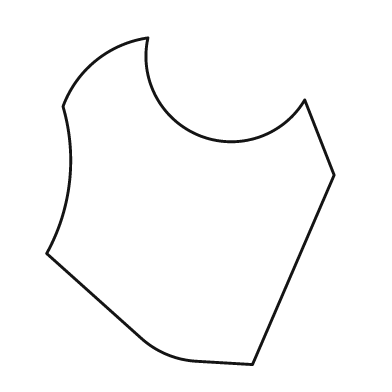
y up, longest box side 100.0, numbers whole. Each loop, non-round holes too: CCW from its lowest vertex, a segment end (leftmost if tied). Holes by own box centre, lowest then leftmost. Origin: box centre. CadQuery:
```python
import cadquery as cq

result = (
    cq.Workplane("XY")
    .moveTo(19.0, -50.0)
    .lineTo(44.0, 8.0)
    .lineTo(35.0, 31.0)
    .threePointArc((3.0, 20.0), (-13.0, 50.0))
    .threePointArc((-29.0, 43.0), (-39.0, 29.0))
    .threePointArc((-37.0, 6.0), (-44.0, -16.0))
    .lineTo(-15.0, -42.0)
    .threePointArc((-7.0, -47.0), (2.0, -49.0))
    .close()
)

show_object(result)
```